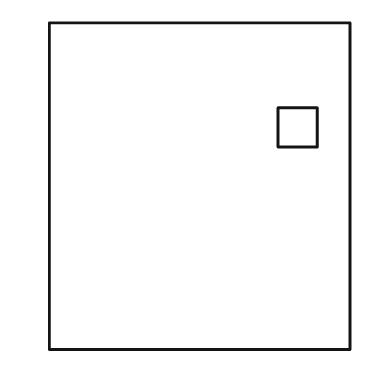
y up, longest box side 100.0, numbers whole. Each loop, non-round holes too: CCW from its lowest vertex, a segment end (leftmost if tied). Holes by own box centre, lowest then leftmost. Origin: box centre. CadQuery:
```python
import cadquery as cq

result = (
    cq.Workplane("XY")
    .moveTo(-46.0, -50.0)
    .lineTo(46.0, -50.0)
    .lineTo(46.0, 50.0)
    .lineTo(-46.0, 50.0)
    .close()
    .moveTo(24.0, 12.0)
    .lineTo(36.0, 12.0)
    .lineTo(36.0, 24.0)
    .lineTo(24.0, 24.0)
    .close()
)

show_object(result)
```